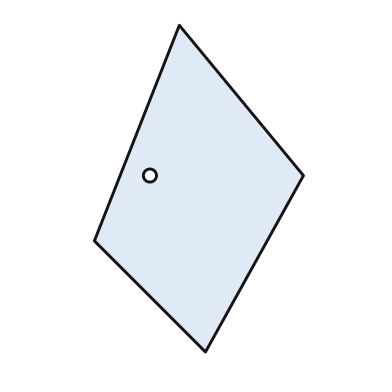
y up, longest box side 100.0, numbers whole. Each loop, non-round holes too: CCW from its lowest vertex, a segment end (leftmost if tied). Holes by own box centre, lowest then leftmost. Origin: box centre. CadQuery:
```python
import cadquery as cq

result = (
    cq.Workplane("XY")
    .moveTo(2.0, -50.0)
    .lineTo(32.0, 4.0)
    .lineTo(-6.0, 50.0)
    .lineTo(-32.0, -16.0)
    .close()
    .moveTo(-15.0, 4.0)
    .circle(2.0)
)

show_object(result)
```